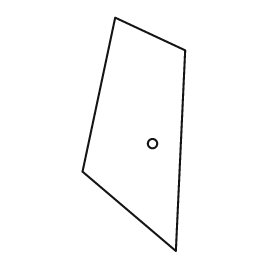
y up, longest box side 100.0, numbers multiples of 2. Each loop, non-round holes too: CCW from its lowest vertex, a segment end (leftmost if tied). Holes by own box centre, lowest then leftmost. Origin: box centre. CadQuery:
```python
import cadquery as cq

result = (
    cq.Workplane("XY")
    .moveTo(18.0, -50.0)
    .lineTo(22.0, 36.0)
    .lineTo(-8.0, 50.0)
    .lineTo(-22.0, -16.0)
    .close()
    .moveTo(8.0, -4.0)
    .circle(2.0)
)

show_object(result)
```